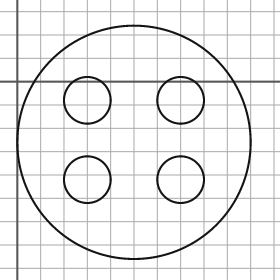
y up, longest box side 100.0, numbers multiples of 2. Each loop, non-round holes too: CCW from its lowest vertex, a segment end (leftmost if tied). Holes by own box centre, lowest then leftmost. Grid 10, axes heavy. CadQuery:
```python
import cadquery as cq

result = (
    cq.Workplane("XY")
    .moveTo(50.0, -26.0)
    .circle(50.0)
    .moveTo(30.0, -42.0)
    .circle(10.0)
    .moveTo(70.0, -42.0)
    .circle(10.0)
    .moveTo(30.0, -8.0)
    .circle(10.0)
    .moveTo(70.0, -8.0)
    .circle(10.0)
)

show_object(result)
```